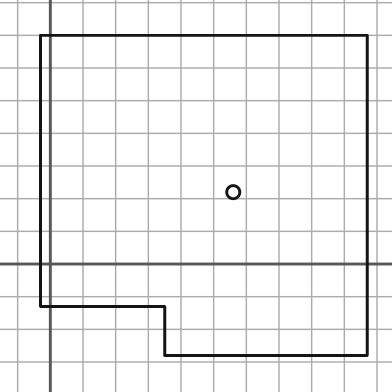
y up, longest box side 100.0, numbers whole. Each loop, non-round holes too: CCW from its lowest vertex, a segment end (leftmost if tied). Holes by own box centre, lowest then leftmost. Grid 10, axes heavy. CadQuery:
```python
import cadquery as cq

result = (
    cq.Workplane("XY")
    .moveTo(35.0, -28.0)
    .lineTo(97.0, -28.0)
    .lineTo(97.0, 70.0)
    .lineTo(-3.0, 70.0)
    .lineTo(-3.0, -13.0)
    .lineTo(35.0, -13.0)
    .close()
    .moveTo(56.0, 22.0)
    .circle(2.0)
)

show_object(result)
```